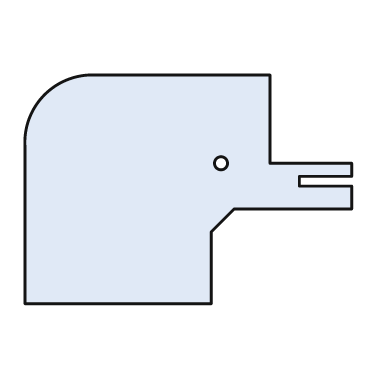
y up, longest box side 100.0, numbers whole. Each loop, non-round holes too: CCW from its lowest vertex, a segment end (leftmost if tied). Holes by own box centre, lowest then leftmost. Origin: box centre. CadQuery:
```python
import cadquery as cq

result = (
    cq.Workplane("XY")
    .moveTo(-50.0, -35.0)
    .lineTo(7.0, -35.0)
    .lineTo(7.0, -13.0)
    .lineTo(14.0, -6.0)
    .lineTo(50.0, -6.0)
    .lineTo(50.0, 1.0)
    .lineTo(34.0, 1.0)
    .lineTo(34.0, 4.0)
    .lineTo(50.0, 4.0)
    .lineTo(50.0, 8.0)
    .lineTo(25.0, 8.0)
    .lineTo(25.0, 35.0)
    .lineTo(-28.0, 35.0)
    .threePointArc((-44.0, 29.0), (-50.0, 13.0))
    .close()
    .moveTo(10.0, 8.0)
    .circle(2.0)
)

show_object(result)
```